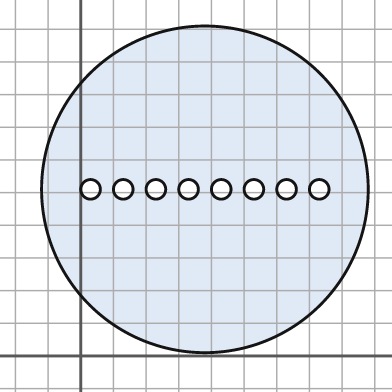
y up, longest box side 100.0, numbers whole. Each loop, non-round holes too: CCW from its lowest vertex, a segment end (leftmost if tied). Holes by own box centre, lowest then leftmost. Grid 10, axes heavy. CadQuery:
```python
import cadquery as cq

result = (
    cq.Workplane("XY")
    .moveTo(38.0, 51.0)
    .circle(50.0)
    .moveTo(3.0, 51.0)
    .circle(3.0)
    .moveTo(13.0, 51.0)
    .circle(3.0)
    .moveTo(23.0, 51.0)
    .circle(3.0)
    .moveTo(33.0, 51.0)
    .circle(3.0)
    .moveTo(43.0, 51.0)
    .circle(3.0)
    .moveTo(53.0, 51.0)
    .circle(3.0)
    .moveTo(63.0, 51.0)
    .circle(3.0)
    .moveTo(73.0, 51.0)
    .circle(3.0)
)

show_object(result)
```